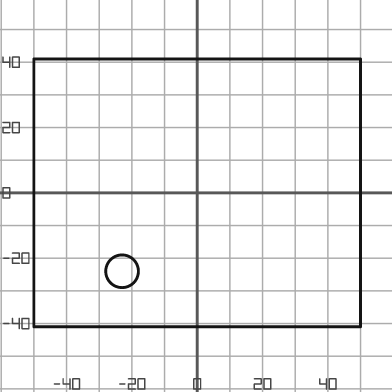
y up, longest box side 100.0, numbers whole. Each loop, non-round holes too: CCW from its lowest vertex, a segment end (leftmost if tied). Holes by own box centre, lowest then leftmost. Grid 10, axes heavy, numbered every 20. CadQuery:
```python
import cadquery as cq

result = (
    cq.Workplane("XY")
    .moveTo(-50.0, -41.0)
    .lineTo(50.0, -41.0)
    .lineTo(50.0, 41.0)
    .lineTo(-50.0, 41.0)
    .close()
    .moveTo(-23.0, -24.0)
    .circle(5.0)
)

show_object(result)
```